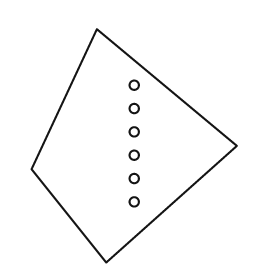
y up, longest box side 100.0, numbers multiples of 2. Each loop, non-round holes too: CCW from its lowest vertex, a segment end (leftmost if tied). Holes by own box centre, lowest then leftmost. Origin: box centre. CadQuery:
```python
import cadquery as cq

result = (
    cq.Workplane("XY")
    .moveTo(-12.0, -50.0)
    .lineTo(44.0, 0.0)
    .lineTo(-16.0, 50.0)
    .lineTo(-44.0, -10.0)
    .close()
    .moveTo(0.0, -24.0)
    .circle(2.0)
    .moveTo(0.0, -14.0)
    .circle(2.0)
    .moveTo(0.0, -4.0)
    .circle(2.0)
    .moveTo(0.0, 6.0)
    .circle(2.0)
    .moveTo(0.0, 16.0)
    .circle(2.0)
    .moveTo(0.0, 26.0)
    .circle(2.0)
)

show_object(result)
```